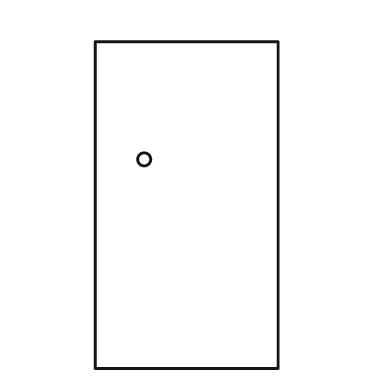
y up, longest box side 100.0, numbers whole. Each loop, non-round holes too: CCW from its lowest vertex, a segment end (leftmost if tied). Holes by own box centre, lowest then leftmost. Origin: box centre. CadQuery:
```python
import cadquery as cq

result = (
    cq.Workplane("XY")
    .moveTo(-28.0, -50.0)
    .lineTo(28.0, -50.0)
    .lineTo(28.0, 50.0)
    .lineTo(-28.0, 50.0)
    .close()
    .moveTo(-13.0, 14.0)
    .circle(2.0)
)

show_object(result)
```